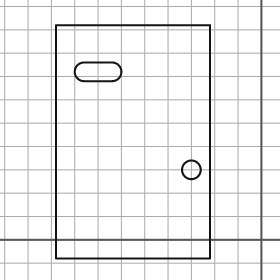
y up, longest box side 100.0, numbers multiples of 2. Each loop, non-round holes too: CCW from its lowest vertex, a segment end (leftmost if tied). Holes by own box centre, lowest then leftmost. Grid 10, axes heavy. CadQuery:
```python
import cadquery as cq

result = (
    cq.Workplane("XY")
    .moveTo(-88.0, -8.0)
    .lineTo(-22.0, -8.0)
    .lineTo(-22.0, 92.0)
    .lineTo(-88.0, 92.0)
    .close()
    .moveTo(-30.0, 30.0)
    .circle(4.0)
    .moveTo(-76.0, 68.0)
    .lineTo(-64.0, 68.0)
    .threePointArc((-60.0, 72.0), (-64.0, 76.0))
    .lineTo(-76.0, 76.0)
    .threePointArc((-80.0, 72.0), (-76.0, 68.0))
    .close()
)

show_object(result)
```